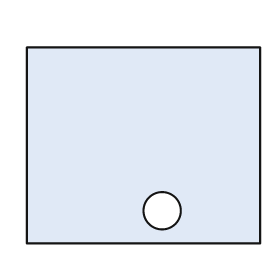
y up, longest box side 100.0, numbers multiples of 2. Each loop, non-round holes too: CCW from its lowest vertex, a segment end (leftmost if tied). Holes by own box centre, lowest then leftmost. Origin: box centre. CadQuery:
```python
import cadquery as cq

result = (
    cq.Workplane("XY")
    .moveTo(-50.0, -42.0)
    .lineTo(50.0, -42.0)
    .lineTo(50.0, 42.0)
    .lineTo(-50.0, 42.0)
    .close()
    .moveTo(8.0, -28.0)
    .circle(8.0)
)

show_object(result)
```